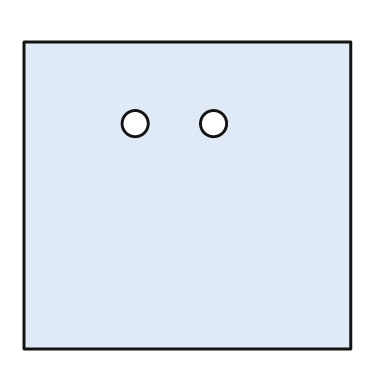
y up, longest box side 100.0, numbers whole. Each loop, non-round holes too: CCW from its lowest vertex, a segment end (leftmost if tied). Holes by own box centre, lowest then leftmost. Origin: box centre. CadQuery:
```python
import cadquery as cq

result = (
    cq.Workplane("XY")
    .moveTo(-50.0, -47.0)
    .lineTo(50.0, -47.0)
    .lineTo(50.0, 47.0)
    .lineTo(-50.0, 47.0)
    .close()
    .moveTo(-16.0, 22.0)
    .circle(4.0)
    .moveTo(8.0, 22.0)
    .circle(4.0)
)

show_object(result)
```